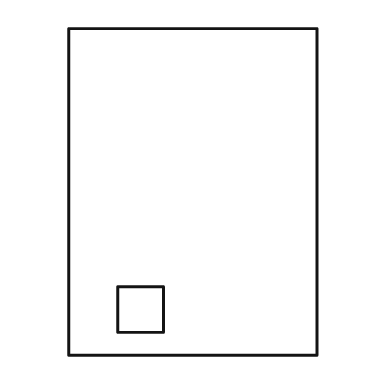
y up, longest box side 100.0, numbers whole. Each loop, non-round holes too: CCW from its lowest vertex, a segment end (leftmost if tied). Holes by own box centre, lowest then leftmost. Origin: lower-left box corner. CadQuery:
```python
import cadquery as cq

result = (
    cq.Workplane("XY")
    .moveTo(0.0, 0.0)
    .lineTo(76.0, 0.0)
    .lineTo(76.0, 100.0)
    .lineTo(0.0, 100.0)
    .close()
    .moveTo(15.0, 7.0)
    .lineTo(29.0, 7.0)
    .lineTo(29.0, 21.0)
    .lineTo(15.0, 21.0)
    .close()
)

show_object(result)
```